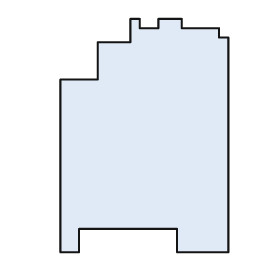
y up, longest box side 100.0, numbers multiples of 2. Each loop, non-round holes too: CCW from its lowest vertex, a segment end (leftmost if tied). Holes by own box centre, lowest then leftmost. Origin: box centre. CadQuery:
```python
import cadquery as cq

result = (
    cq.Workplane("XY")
    .moveTo(-36.0, -50.0)
    .lineTo(-28.0, -50.0)
    .lineTo(-28.0, -40.0)
    .lineTo(14.0, -40.0)
    .lineTo(14.0, -50.0)
    .lineTo(36.0, -50.0)
    .lineTo(36.0, 42.0)
    .lineTo(32.0, 42.0)
    .lineTo(32.0, 46.0)
    .lineTo(16.0, 46.0)
    .lineTo(16.0, 50.0)
    .lineTo(6.0, 50.0)
    .lineTo(6.0, 46.0)
    .lineTo(-2.0, 46.0)
    .lineTo(-2.0, 50.0)
    .lineTo(-6.0, 50.0)
    .lineTo(-6.0, 40.0)
    .lineTo(-20.0, 40.0)
    .lineTo(-20.0, 24.0)
    .lineTo(-36.0, 24.0)
    .close()
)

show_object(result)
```